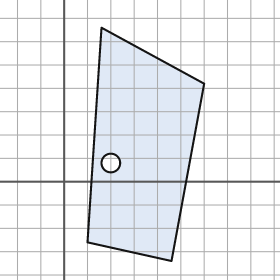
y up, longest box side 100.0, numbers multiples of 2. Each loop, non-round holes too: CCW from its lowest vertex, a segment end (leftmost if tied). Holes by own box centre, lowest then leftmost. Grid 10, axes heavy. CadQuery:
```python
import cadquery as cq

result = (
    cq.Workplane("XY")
    .moveTo(46.0, -34.0)
    .lineTo(60.0, 42.0)
    .lineTo(16.0, 66.0)
    .lineTo(10.0, -26.0)
    .close()
    .moveTo(20.0, 8.0)
    .circle(4.0)
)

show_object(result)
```